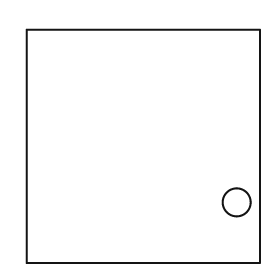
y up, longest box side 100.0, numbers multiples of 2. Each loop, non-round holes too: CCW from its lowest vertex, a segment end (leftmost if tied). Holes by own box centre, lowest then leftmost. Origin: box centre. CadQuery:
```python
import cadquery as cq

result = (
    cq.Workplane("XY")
    .moveTo(-50.0, -50.0)
    .lineTo(50.0, -50.0)
    .lineTo(50.0, 50.0)
    .lineTo(-50.0, 50.0)
    .close()
    .moveTo(40.0, -24.0)
    .circle(6.0)
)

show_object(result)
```